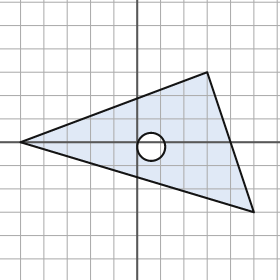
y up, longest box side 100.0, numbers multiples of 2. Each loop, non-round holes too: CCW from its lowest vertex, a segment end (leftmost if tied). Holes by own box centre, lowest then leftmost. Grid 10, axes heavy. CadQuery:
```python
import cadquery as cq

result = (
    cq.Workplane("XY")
    .moveTo(50.0, -30.0)
    .lineTo(30.0, 30.0)
    .lineTo(-50.0, 0.0)
    .close()
    .moveTo(6.0, -2.0)
    .circle(6.0)
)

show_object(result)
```